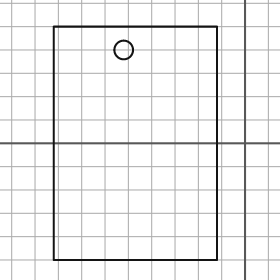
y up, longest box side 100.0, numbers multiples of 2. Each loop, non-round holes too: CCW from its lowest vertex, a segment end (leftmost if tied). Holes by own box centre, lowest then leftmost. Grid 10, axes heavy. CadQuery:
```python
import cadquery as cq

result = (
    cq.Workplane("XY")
    .moveTo(-82.0, -50.0)
    .lineTo(-12.0, -50.0)
    .lineTo(-12.0, 50.0)
    .lineTo(-82.0, 50.0)
    .close()
    .moveTo(-52.0, 40.0)
    .circle(4.0)
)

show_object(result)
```